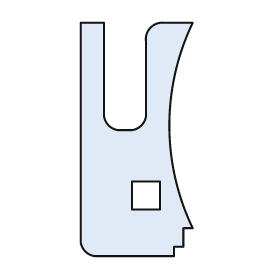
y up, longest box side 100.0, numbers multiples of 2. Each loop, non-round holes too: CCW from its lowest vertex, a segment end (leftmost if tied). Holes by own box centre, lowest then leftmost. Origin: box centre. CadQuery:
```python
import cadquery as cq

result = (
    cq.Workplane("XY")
    .moveTo(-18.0, -50.0)
    .lineTo(16.0, -50.0)
    .lineTo(16.0, -46.0)
    .lineTo(20.0, -46.0)
    .lineTo(20.0, -38.0)
    .lineTo(24.0, -38.0)
    .threePointArc((14.0, 6.0), (24.0, 50.0))
    .lineTo(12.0, 50.0)
    .threePointArc((6.0, 48.0), (4.0, 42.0))
    .lineTo(4.0, 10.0)
    .threePointArc((2.0, 6.0), (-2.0, 4.0))
    .lineTo(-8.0, 4.0)
    .threePointArc((-12.0, 6.0), (-14.0, 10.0))
    .lineTo(-14.0, 50.0)
    .lineTo(-24.0, 50.0)
    .lineTo(-24.0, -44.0)
    .threePointArc((-22.0, -48.0), (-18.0, -50.0))
    .close()
    .moveTo(-2.0, -30.0)
    .lineTo(10.0, -30.0)
    .lineTo(10.0, -18.0)
    .lineTo(-2.0, -18.0)
    .close()
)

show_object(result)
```